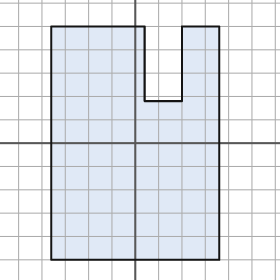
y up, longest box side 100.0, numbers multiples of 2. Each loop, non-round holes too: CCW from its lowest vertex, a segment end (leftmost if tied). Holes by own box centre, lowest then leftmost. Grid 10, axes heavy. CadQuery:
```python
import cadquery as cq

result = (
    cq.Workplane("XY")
    .moveTo(-36.0, -50.0)
    .lineTo(36.0, -50.0)
    .lineTo(36.0, 50.0)
    .lineTo(20.0, 50.0)
    .lineTo(20.0, 18.0)
    .lineTo(4.0, 18.0)
    .lineTo(4.0, 50.0)
    .lineTo(-36.0, 50.0)
    .close()
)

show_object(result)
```